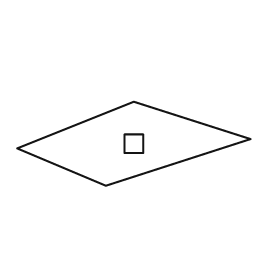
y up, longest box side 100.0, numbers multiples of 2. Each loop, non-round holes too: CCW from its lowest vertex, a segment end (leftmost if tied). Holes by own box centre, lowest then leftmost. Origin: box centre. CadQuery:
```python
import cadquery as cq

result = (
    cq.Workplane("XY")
    .moveTo(-12.0, -18.0)
    .lineTo(50.0, 2.0)
    .lineTo(0.0, 18.0)
    .lineTo(-50.0, -2.0)
    .close()
    .moveTo(-4.0, -4.0)
    .lineTo(4.0, -4.0)
    .lineTo(4.0, 4.0)
    .lineTo(-4.0, 4.0)
    .close()
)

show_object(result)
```